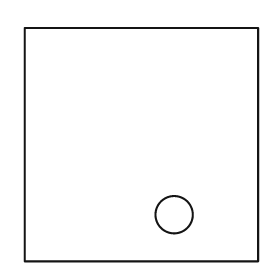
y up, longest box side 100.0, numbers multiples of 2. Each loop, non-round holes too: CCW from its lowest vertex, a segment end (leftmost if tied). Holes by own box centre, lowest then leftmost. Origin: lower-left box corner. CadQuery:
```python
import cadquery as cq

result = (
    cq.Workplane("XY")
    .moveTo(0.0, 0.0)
    .lineTo(100.0, 0.0)
    .lineTo(100.0, 100.0)
    .lineTo(0.0, 100.0)
    .close()
    .moveTo(64.0, 20.0)
    .circle(8.0)
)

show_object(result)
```